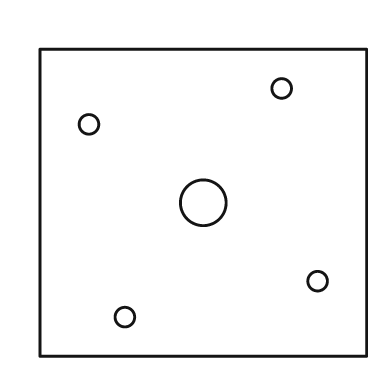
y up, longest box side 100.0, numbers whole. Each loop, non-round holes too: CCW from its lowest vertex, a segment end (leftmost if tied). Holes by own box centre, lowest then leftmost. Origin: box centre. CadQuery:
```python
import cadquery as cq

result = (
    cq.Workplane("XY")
    .moveTo(-50.0, -47.0)
    .lineTo(50.0, -47.0)
    .lineTo(50.0, 47.0)
    .lineTo(-50.0, 47.0)
    .close()
    .moveTo(-24.0, -35.0)
    .circle(3.0)
    .moveTo(35.0, -24.0)
    .circle(3.0)
    .moveTo(0.0, 0.0)
    .circle(7.0)
    .moveTo(-35.0, 24.0)
    .circle(3.0)
    .moveTo(24.0, 35.0)
    .circle(3.0)
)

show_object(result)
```